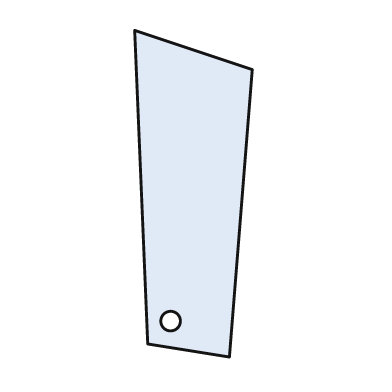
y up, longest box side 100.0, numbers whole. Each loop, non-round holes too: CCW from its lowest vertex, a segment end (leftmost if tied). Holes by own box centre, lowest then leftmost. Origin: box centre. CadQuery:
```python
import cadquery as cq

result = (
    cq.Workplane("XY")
    .moveTo(11.0, -50.0)
    .lineTo(18.0, 38.0)
    .lineTo(-18.0, 50.0)
    .lineTo(-14.0, -46.0)
    .close()
    .moveTo(-7.0, -39.0)
    .circle(3.0)
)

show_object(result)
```